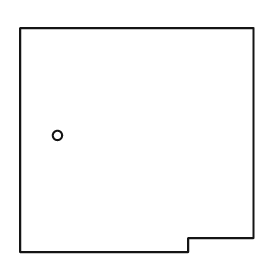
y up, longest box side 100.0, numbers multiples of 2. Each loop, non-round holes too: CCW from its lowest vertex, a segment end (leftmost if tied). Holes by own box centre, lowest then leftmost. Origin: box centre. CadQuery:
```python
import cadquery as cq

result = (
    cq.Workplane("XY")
    .moveTo(-50.0, -48.0)
    .lineTo(22.0, -48.0)
    .lineTo(22.0, -42.0)
    .lineTo(50.0, -42.0)
    .lineTo(50.0, 48.0)
    .lineTo(-50.0, 48.0)
    .close()
    .moveTo(-34.0, 2.0)
    .circle(2.0)
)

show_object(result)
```